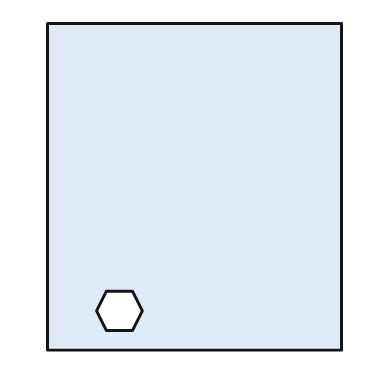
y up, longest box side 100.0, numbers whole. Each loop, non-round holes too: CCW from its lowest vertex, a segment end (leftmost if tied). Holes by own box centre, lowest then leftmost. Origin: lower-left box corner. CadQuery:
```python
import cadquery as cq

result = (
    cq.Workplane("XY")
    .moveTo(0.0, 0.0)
    .lineTo(90.0, 0.0)
    .lineTo(90.0, 100.0)
    .lineTo(0.0, 100.0)
    .close()
    .moveTo(18.0, 6.0)
    .lineTo(26.0, 6.0)
    .lineTo(29.0, 12.0)
    .lineTo(26.0, 18.0)
    .lineTo(18.0, 18.0)
    .lineTo(15.0, 12.0)
    .close()
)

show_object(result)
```